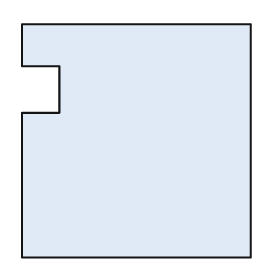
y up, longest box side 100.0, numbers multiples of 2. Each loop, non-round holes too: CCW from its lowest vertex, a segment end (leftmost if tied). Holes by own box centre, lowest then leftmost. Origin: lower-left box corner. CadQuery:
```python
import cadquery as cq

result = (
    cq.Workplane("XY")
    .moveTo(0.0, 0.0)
    .lineTo(98.0, 0.0)
    .lineTo(98.0, 100.0)
    .lineTo(0.0, 100.0)
    .lineTo(0.0, 82.0)
    .lineTo(16.0, 82.0)
    .lineTo(16.0, 62.0)
    .lineTo(0.0, 62.0)
    .close()
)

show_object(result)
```